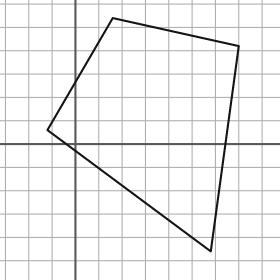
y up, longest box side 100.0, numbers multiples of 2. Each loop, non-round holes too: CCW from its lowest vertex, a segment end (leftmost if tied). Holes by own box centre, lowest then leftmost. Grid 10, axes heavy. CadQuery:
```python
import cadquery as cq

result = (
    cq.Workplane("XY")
    .moveTo(58.0, -46.0)
    .lineTo(70.0, 42.0)
    .lineTo(16.0, 54.0)
    .lineTo(-12.0, 6.0)
    .close()
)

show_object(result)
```